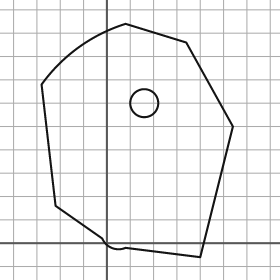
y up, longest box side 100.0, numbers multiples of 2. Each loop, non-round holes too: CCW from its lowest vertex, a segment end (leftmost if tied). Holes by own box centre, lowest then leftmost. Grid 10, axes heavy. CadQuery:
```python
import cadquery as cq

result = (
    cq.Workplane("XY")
    .moveTo(40.0, -6.0)
    .lineTo(54.0, 50.0)
    .lineTo(34.0, 86.0)
    .lineTo(8.0, 94.0)
    .threePointArc((-12.0, 84.0), (-28.0, 68.0))
    .lineTo(-22.0, 16.0)
    .lineTo(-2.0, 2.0)
    .threePointArc((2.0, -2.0), (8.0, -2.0))
    .close()
    .moveTo(16.0, 60.0)
    .circle(6.0)
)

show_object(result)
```